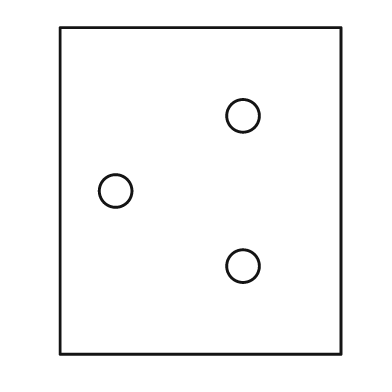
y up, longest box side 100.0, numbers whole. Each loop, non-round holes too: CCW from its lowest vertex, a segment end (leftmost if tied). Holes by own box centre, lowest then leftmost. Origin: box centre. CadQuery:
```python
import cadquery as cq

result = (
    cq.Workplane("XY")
    .moveTo(-43.0, -50.0)
    .lineTo(43.0, -50.0)
    .lineTo(43.0, 50.0)
    .lineTo(-43.0, 50.0)
    .close()
    .moveTo(13.0, -23.0)
    .circle(5.0)
    .moveTo(-26.0, 0.0)
    .circle(5.0)
    .moveTo(13.0, 23.0)
    .circle(5.0)
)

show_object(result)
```